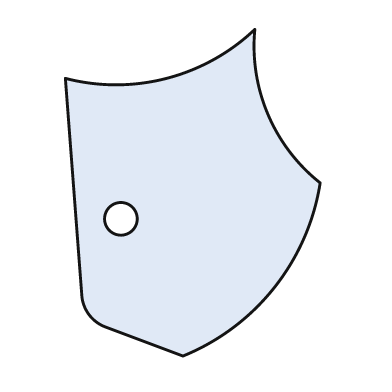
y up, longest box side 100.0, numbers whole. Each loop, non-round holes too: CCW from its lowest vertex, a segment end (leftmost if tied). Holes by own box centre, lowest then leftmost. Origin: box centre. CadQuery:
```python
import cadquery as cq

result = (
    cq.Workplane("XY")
    .moveTo(-3.0, -50.0)
    .threePointArc((25.0, -29.0), (39.0, 3.0))
    .threePointArc((23.0, 24.0), (19.0, 50.0))
    .threePointArc((-8.0, 35.0), (-39.0, 35.0))
    .lineTo(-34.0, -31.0)
    .threePointArc((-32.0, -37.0), (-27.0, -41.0))
    .close()
    .moveTo(-22.0, -8.0)
    .circle(5.0)
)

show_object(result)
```